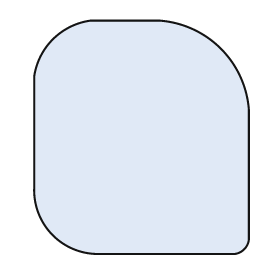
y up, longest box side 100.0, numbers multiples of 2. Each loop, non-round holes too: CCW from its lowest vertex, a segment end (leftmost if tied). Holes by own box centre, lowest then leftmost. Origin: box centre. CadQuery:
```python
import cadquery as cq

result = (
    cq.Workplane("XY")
    .moveTo(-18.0, -50.0)
    .lineTo(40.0, -50.0)
    .threePointArc((44.0, -48.0), (46.0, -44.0))
    .lineTo(46.0, 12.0)
    .threePointArc((34.0, 38.0), (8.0, 50.0))
    .lineTo(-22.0, 50.0)
    .threePointArc((-38.0, 42.0), (-46.0, 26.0))
    .lineTo(-46.0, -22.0)
    .threePointArc((-38.0, -42.0), (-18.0, -50.0))
    .close()
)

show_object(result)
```